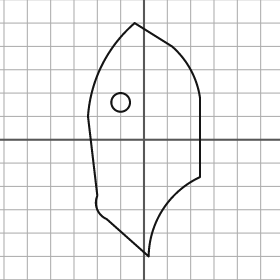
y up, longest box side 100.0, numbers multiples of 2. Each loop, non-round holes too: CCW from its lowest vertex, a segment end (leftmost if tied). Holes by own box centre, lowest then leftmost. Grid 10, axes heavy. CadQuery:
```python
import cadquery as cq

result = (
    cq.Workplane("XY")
    .moveTo(2.0, -50.0)
    .threePointArc((8.0, -30.0), (24.0, -16.0))
    .lineTo(24.0, 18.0)
    .threePointArc((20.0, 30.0), (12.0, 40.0))
    .lineTo(-4.0, 50.0)
    .threePointArc((-18.0, 32.0), (-24.0, 10.0))
    .lineTo(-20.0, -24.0)
    .threePointArc((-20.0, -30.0), (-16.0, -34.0))
    .close()
    .moveTo(-10.0, 16.0)
    .circle(4.0)
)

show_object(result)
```